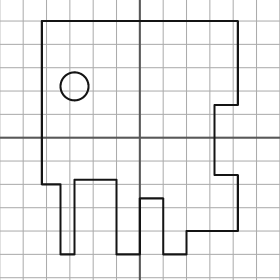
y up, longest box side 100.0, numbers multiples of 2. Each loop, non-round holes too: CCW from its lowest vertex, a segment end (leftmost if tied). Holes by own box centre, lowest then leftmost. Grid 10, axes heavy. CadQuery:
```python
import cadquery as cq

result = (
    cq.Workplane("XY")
    .moveTo(-34.0, -50.0)
    .lineTo(-28.0, -50.0)
    .lineTo(-28.0, -18.0)
    .lineTo(-10.0, -18.0)
    .lineTo(-10.0, -50.0)
    .lineTo(0.0, -50.0)
    .lineTo(0.0, -26.0)
    .lineTo(10.0, -26.0)
    .lineTo(10.0, -50.0)
    .lineTo(20.0, -50.0)
    .lineTo(20.0, -40.0)
    .lineTo(42.0, -40.0)
    .lineTo(42.0, -16.0)
    .lineTo(32.0, -16.0)
    .lineTo(32.0, 14.0)
    .lineTo(42.0, 14.0)
    .lineTo(42.0, 50.0)
    .lineTo(-42.0, 50.0)
    .lineTo(-42.0, -20.0)
    .lineTo(-34.0, -20.0)
    .close()
    .moveTo(-28.0, 22.0)
    .circle(6.0)
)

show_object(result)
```